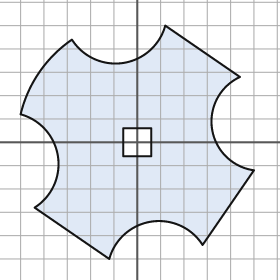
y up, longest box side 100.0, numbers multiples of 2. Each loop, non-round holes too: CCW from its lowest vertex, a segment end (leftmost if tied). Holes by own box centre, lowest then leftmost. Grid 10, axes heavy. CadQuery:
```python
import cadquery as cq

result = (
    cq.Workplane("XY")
    .moveTo(-12.0, -50.0)
    .threePointArc((6.0, -34.0), (28.0, -44.0))
    .lineTo(50.0, -12.0)
    .threePointArc((32.0, 6.0), (44.0, 28.0))
    .lineTo(12.0, 50.0)
    .threePointArc((-6.0, 34.0), (-28.0, 44.0))
    .threePointArc((-42.0, 30.0), (-50.0, 12.0))
    .threePointArc((-34.0, -6.0), (-44.0, -28.0))
    .close()
    .moveTo(-6.0, -6.0)
    .lineTo(6.0, -6.0)
    .lineTo(6.0, 6.0)
    .lineTo(-6.0, 6.0)
    .close()
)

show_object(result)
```